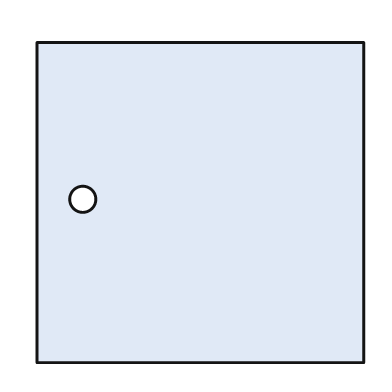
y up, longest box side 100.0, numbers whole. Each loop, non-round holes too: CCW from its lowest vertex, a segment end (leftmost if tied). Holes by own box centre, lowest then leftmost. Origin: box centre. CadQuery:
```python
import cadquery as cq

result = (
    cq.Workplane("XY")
    .moveTo(-50.0, -49.0)
    .lineTo(50.0, -49.0)
    .lineTo(50.0, 49.0)
    .lineTo(-50.0, 49.0)
    .close()
    .moveTo(-36.0, 1.0)
    .circle(4.0)
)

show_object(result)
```